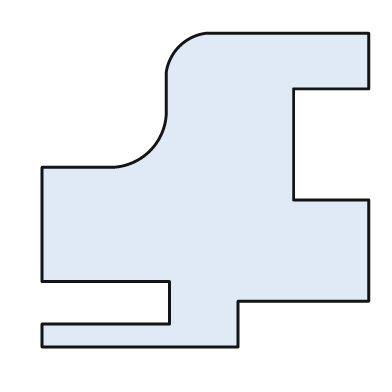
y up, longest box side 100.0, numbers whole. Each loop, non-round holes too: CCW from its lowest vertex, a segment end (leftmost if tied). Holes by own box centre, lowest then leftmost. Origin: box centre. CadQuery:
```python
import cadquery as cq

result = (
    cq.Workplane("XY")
    .moveTo(-50.0, -48.0)
    .lineTo(10.0, -48.0)
    .lineTo(10.0, -34.0)
    .lineTo(50.0, -34.0)
    .lineTo(50.0, -3.0)
    .lineTo(27.0, -3.0)
    .lineTo(27.0, 31.0)
    .lineTo(50.0, 31.0)
    .lineTo(50.0, 48.0)
    .lineTo(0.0, 48.0)
    .threePointArc((-8.0, 44.0), (-12.0, 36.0))
    .lineTo(-12.0, 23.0)
    .threePointArc((-17.0, 12.0), (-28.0, 7.0))
    .lineTo(-50.0, 7.0)
    .lineTo(-50.0, -28.0)
    .lineTo(-11.0, -28.0)
    .lineTo(-11.0, -41.0)
    .lineTo(-50.0, -41.0)
    .close()
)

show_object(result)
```